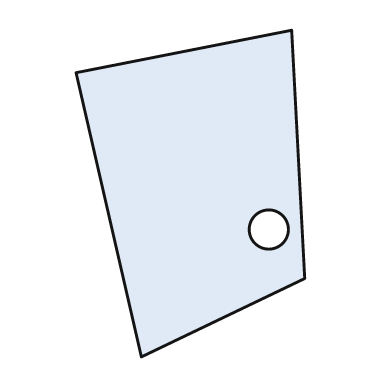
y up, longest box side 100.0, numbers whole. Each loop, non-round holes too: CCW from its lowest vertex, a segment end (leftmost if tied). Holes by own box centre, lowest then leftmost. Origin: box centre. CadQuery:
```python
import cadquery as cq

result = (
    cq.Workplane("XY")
    .moveTo(-15.0, -50.0)
    .lineTo(35.0, -26.0)
    .lineTo(31.0, 50.0)
    .lineTo(-35.0, 37.0)
    .close()
    .moveTo(24.0, -11.0)
    .circle(6.0)
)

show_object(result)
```